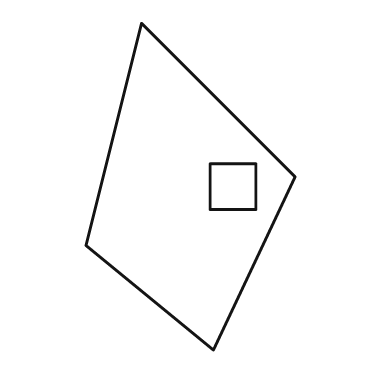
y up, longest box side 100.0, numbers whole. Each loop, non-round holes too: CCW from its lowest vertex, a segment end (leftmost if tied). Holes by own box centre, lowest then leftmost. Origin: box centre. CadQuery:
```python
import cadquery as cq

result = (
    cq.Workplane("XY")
    .moveTo(7.0, -50.0)
    .lineTo(32.0, 3.0)
    .lineTo(-15.0, 50.0)
    .lineTo(-32.0, -18.0)
    .close()
    .moveTo(6.0, -7.0)
    .lineTo(20.0, -7.0)
    .lineTo(20.0, 7.0)
    .lineTo(6.0, 7.0)
    .close()
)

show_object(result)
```